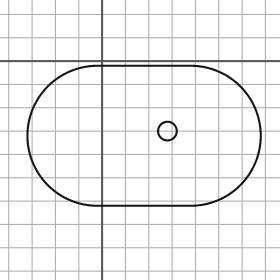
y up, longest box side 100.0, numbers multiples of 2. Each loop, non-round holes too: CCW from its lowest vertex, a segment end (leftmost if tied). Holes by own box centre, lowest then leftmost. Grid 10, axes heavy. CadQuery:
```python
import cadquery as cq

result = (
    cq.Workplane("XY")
    .moveTo(-2.0, -62.0)
    .lineTo(38.0, -62.0)
    .threePointArc((68.0, -32.0), (38.0, -2.0))
    .lineTo(-2.0, -2.0)
    .threePointArc((-32.0, -32.0), (-2.0, -62.0))
    .close()
    .moveTo(28.0, -30.0)
    .circle(4.0)
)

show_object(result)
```